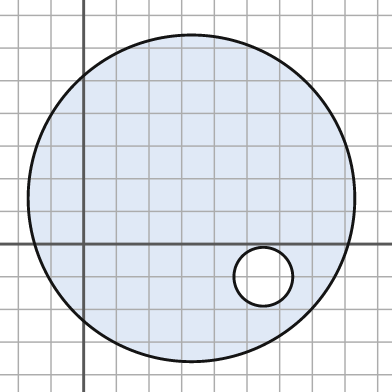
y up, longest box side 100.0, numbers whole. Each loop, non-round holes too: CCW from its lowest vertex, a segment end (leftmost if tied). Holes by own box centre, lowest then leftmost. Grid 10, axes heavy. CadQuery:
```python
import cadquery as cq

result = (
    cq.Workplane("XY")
    .moveTo(33.0, 14.0)
    .circle(50.0)
    .moveTo(55.0, -10.0)
    .circle(9.0)
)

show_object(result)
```